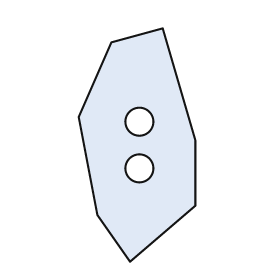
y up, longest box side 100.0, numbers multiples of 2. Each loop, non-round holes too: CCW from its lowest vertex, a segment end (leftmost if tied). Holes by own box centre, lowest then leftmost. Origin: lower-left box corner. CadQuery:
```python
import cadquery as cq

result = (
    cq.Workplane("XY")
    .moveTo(22.0, 0.0)
    .lineTo(50.0, 24.0)
    .lineTo(50.0, 52.0)
    .lineTo(36.0, 100.0)
    .lineTo(14.0, 94.0)
    .lineTo(0.0, 62.0)
    .lineTo(8.0, 20.0)
    .close()
    .moveTo(26.0, 40.0)
    .circle(6.0)
    .moveTo(26.0, 60.0)
    .circle(6.0)
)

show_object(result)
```